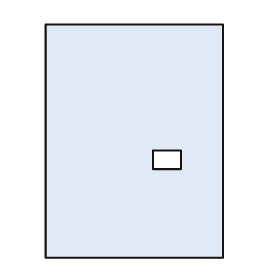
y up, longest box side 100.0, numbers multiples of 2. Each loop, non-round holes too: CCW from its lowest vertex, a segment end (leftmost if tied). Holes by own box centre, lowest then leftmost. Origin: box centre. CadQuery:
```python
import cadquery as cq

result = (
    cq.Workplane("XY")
    .moveTo(-38.0, -50.0)
    .lineTo(38.0, -50.0)
    .lineTo(38.0, 50.0)
    .lineTo(-38.0, 50.0)
    .close()
    .moveTo(8.0, -12.0)
    .lineTo(20.0, -12.0)
    .lineTo(20.0, -4.0)
    .lineTo(8.0, -4.0)
    .close()
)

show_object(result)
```